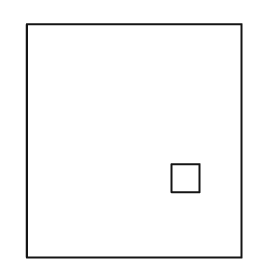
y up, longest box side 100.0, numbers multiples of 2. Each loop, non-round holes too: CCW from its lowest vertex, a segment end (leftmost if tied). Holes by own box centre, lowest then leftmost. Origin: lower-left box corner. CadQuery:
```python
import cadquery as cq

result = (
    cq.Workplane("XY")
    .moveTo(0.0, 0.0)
    .lineTo(92.0, 0.0)
    .lineTo(92.0, 100.0)
    .lineTo(0.0, 100.0)
    .close()
    .moveTo(62.0, 28.0)
    .lineTo(74.0, 28.0)
    .lineTo(74.0, 40.0)
    .lineTo(62.0, 40.0)
    .close()
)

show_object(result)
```